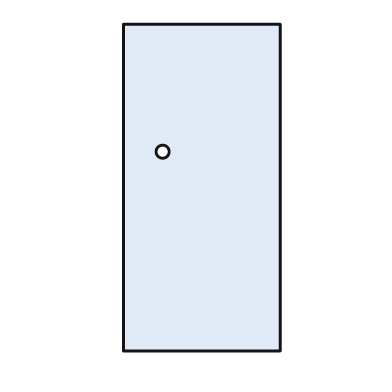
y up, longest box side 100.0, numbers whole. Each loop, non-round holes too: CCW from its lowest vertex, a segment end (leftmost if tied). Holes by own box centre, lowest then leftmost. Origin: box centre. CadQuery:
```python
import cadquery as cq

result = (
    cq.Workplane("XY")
    .moveTo(-24.0, -50.0)
    .lineTo(24.0, -50.0)
    .lineTo(24.0, 50.0)
    .lineTo(-24.0, 50.0)
    .close()
    .moveTo(-12.0, 11.0)
    .circle(2.0)
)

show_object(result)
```